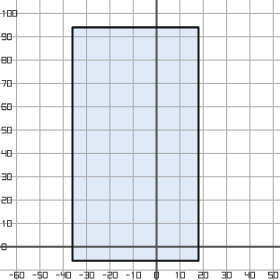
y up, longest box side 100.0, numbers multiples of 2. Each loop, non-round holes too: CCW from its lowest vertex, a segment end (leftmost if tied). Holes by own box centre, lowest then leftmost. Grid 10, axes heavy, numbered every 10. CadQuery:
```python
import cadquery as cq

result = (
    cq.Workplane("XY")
    .moveTo(-36.0, -6.0)
    .lineTo(18.0, -6.0)
    .lineTo(18.0, 94.0)
    .lineTo(-36.0, 94.0)
    .close()
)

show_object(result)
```